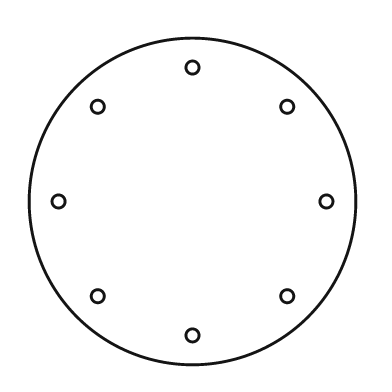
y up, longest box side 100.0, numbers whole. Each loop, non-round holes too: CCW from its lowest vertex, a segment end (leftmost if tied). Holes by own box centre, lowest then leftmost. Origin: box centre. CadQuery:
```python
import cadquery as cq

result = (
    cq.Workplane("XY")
    .moveTo(0.0, 0.0)
    .circle(50.0)
    .moveTo(0.0, -41.0)
    .circle(2.0)
    .moveTo(-29.0, -29.0)
    .circle(2.0)
    .moveTo(29.0, -29.0)
    .circle(2.0)
    .moveTo(-41.0, 0.0)
    .circle(2.0)
    .moveTo(41.0, 0.0)
    .circle(2.0)
    .moveTo(-29.0, 29.0)
    .circle(2.0)
    .moveTo(29.0, 29.0)
    .circle(2.0)
    .moveTo(0.0, 41.0)
    .circle(2.0)
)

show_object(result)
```